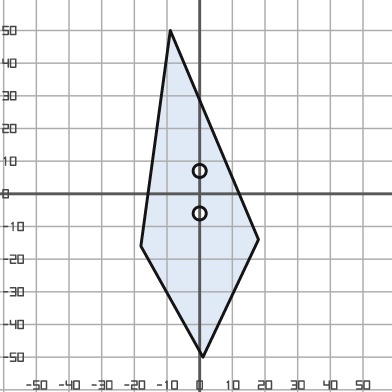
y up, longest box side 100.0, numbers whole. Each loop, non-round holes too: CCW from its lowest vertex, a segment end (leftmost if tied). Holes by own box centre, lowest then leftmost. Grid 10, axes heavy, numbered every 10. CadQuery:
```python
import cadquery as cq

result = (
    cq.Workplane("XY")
    .moveTo(1.0, -50.0)
    .lineTo(18.0, -14.0)
    .lineTo(-9.0, 50.0)
    .lineTo(-18.0, -16.0)
    .close()
    .moveTo(0.0, -6.0)
    .circle(2.0)
    .moveTo(0.0, 7.0)
    .circle(2.0)
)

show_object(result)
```